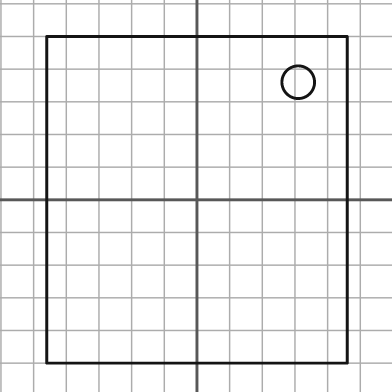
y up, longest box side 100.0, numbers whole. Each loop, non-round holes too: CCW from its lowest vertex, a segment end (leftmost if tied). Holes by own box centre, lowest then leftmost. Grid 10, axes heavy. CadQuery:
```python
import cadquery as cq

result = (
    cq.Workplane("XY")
    .moveTo(-46.0, -50.0)
    .lineTo(46.0, -50.0)
    .lineTo(46.0, 50.0)
    .lineTo(-46.0, 50.0)
    .close()
    .moveTo(31.0, 36.0)
    .circle(5.0)
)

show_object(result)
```